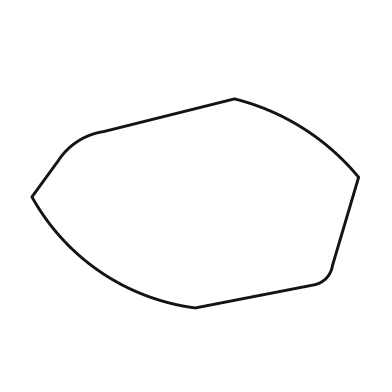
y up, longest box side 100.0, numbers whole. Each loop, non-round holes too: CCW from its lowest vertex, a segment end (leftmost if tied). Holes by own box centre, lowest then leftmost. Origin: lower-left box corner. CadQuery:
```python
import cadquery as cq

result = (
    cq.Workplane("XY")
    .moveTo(50.0, 0.0)
    .lineTo(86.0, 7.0)
    .threePointArc((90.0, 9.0), (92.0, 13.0))
    .lineTo(100.0, 40.0)
    .threePointArc((83.0, 55.0), (62.0, 64.0))
    .lineTo(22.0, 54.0)
    .threePointArc((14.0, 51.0), (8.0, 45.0))
    .lineTo(0.0, 34.0)
    .threePointArc((21.0, 11.0), (50.0, 0.0))
    .close()
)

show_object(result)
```